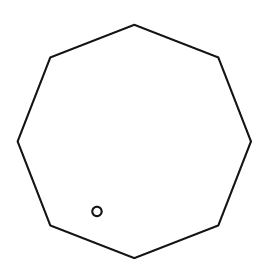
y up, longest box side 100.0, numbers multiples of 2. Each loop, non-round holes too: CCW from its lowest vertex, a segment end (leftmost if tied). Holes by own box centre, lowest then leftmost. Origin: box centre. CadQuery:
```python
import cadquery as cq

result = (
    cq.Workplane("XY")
    .moveTo(0.0, -50.0)
    .lineTo(36.0, -36.0)
    .lineTo(50.0, 0.0)
    .lineTo(36.0, 36.0)
    .lineTo(0.0, 50.0)
    .lineTo(-36.0, 36.0)
    .lineTo(-50.0, 0.0)
    .lineTo(-36.0, -36.0)
    .close()
    .moveTo(-16.0, -30.0)
    .circle(2.0)
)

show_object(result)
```